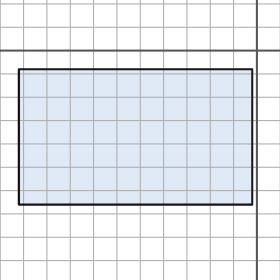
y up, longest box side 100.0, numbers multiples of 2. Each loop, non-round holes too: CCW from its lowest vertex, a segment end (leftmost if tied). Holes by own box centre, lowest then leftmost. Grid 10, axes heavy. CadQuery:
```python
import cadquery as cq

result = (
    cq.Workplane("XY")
    .moveTo(-102.0, -66.0)
    .lineTo(-2.0, -66.0)
    .lineTo(-2.0, -8.0)
    .lineTo(-102.0, -8.0)
    .close()
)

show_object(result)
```